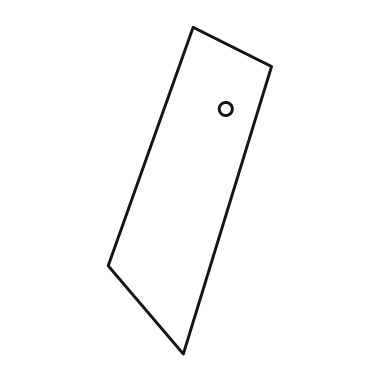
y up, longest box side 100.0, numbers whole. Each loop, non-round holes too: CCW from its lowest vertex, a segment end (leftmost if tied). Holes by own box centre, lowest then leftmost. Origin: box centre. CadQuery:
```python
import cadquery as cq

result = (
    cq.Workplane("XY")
    .moveTo(-2.0, -50.0)
    .lineTo(25.0, 38.0)
    .lineTo(1.0, 50.0)
    .lineTo(-25.0, -23.0)
    .close()
    .moveTo(11.0, 25.0)
    .circle(2.0)
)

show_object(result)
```